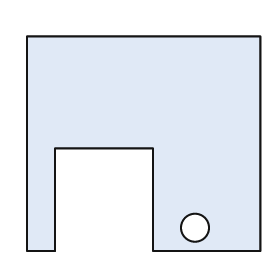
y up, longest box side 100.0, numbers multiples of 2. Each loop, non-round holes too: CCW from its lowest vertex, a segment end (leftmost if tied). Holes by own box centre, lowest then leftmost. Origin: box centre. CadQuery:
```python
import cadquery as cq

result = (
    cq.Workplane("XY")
    .moveTo(-50.0, -46.0)
    .lineTo(-38.0, -46.0)
    .lineTo(-38.0, -2.0)
    .lineTo(4.0, -2.0)
    .lineTo(4.0, -46.0)
    .lineTo(50.0, -46.0)
    .lineTo(50.0, 46.0)
    .lineTo(-50.0, 46.0)
    .close()
    .moveTo(22.0, -36.0)
    .circle(6.0)
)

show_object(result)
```